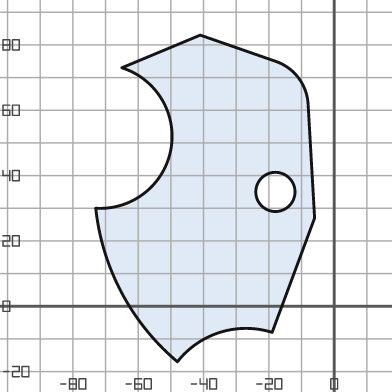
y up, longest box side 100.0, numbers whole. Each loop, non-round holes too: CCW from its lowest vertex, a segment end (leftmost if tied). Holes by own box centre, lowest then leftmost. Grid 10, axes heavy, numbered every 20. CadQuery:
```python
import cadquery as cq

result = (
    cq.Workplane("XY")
    .moveTo(-48.0, -17.0)
    .threePointArc((-35.0, -8.0), (-19.0, -8.0))
    .lineTo(-6.0, 27.0)
    .lineTo(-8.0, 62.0)
    .threePointArc((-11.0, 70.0), (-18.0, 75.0))
    .lineTo(-41.0, 83.0)
    .lineTo(-65.0, 73.0)
    .threePointArc((-50.0, 48.0), (-73.0, 30.0))
    .threePointArc((-65.0, 4.0), (-48.0, -17.0))
    .close()
    .moveTo(-18.0, 35.0)
    .circle(6.0)
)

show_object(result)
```